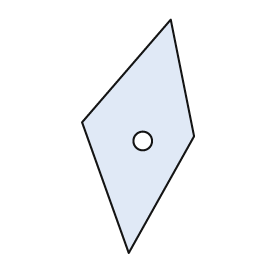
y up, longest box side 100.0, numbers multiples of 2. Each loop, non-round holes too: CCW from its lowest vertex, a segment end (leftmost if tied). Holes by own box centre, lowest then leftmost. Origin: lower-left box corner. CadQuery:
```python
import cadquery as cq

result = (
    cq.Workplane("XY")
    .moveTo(20.0, 0.0)
    .lineTo(48.0, 50.0)
    .lineTo(38.0, 100.0)
    .lineTo(0.0, 56.0)
    .close()
    .moveTo(26.0, 48.0)
    .circle(4.0)
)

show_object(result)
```